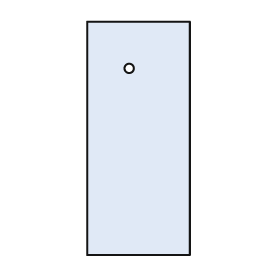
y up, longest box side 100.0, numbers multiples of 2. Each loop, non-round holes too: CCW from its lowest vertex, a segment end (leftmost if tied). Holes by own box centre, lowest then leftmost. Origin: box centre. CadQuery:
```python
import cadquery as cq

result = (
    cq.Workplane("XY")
    .moveTo(-22.0, -50.0)
    .lineTo(22.0, -50.0)
    .lineTo(22.0, 50.0)
    .lineTo(-22.0, 50.0)
    .close()
    .moveTo(-4.0, 30.0)
    .circle(2.0)
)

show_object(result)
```